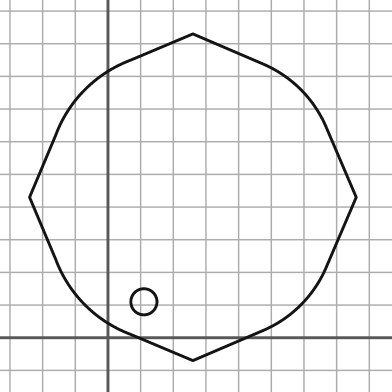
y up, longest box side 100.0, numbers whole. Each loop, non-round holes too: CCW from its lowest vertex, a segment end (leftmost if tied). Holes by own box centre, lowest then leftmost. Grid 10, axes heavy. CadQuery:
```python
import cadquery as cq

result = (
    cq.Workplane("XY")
    .moveTo(26.0, -7.0)
    .lineTo(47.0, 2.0)
    .threePointArc((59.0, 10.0), (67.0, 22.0))
    .lineTo(76.0, 43.0)
    .lineTo(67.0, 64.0)
    .threePointArc((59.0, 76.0), (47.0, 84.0))
    .lineTo(26.0, 93.0)
    .lineTo(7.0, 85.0)
    .threePointArc((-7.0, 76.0), (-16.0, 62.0))
    .lineTo(-24.0, 43.0)
    .lineTo(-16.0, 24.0)
    .threePointArc((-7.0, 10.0), (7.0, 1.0))
    .close()
    .moveTo(11.0, 11.0)
    .circle(4.0)
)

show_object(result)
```